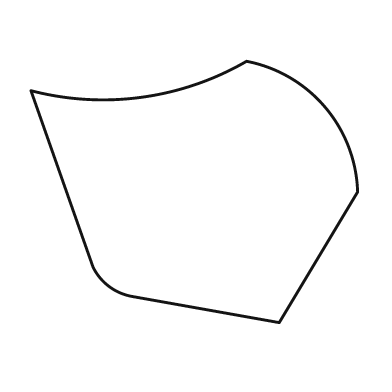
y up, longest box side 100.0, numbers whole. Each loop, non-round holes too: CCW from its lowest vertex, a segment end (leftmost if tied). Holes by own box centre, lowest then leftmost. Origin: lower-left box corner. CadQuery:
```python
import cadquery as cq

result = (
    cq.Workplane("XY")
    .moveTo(76.0, 0.0)
    .lineTo(100.0, 40.0)
    .threePointArc((90.0, 66.0), (66.0, 80.0))
    .threePointArc((34.0, 69.0), (0.0, 71.0))
    .lineTo(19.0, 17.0)
    .threePointArc((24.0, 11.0), (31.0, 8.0))
    .close()
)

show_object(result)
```